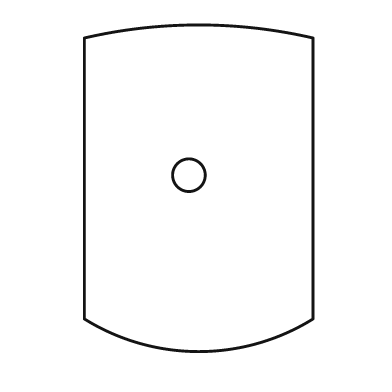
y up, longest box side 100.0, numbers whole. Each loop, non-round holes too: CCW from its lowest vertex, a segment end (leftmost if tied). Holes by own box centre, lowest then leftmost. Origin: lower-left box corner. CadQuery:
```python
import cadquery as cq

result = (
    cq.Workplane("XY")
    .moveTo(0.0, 10.0)
    .threePointArc((35.0, 0.0), (70.0, 10.0))
    .lineTo(70.0, 96.0)
    .threePointArc((35.0, 100.0), (0.0, 96.0))
    .close()
    .moveTo(32.0, 54.0)
    .circle(5.0)
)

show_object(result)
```